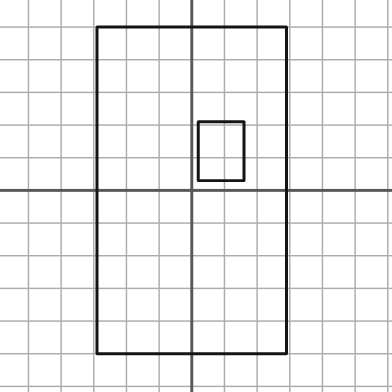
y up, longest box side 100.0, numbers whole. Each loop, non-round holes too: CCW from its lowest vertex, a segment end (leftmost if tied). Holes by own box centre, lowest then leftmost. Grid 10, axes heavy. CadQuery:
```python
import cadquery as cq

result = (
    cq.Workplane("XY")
    .moveTo(-29.0, -50.0)
    .lineTo(29.0, -50.0)
    .lineTo(29.0, 50.0)
    .lineTo(-29.0, 50.0)
    .close()
    .moveTo(2.0, 3.0)
    .lineTo(16.0, 3.0)
    .lineTo(16.0, 21.0)
    .lineTo(2.0, 21.0)
    .close()
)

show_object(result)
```